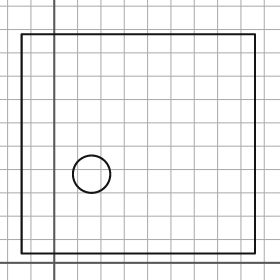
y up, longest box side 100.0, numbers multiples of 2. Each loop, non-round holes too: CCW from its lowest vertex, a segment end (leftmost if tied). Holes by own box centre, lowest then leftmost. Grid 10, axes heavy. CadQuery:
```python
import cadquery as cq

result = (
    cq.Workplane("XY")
    .moveTo(-14.0, 4.0)
    .lineTo(86.0, 4.0)
    .lineTo(86.0, 98.0)
    .lineTo(-14.0, 98.0)
    .close()
    .moveTo(16.0, 38.0)
    .circle(8.0)
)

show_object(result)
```